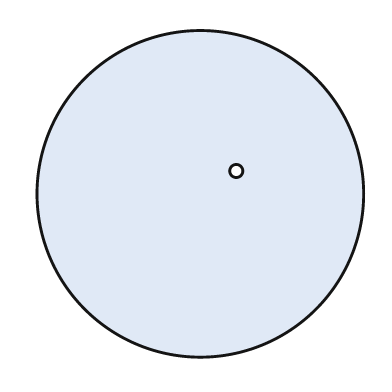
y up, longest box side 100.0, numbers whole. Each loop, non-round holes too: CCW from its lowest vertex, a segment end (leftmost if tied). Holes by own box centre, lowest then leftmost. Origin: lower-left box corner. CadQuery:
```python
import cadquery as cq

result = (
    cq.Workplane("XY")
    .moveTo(50.0, 50.0)
    .circle(50.0)
    .moveTo(61.0, 57.0)
    .circle(2.0)
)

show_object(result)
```